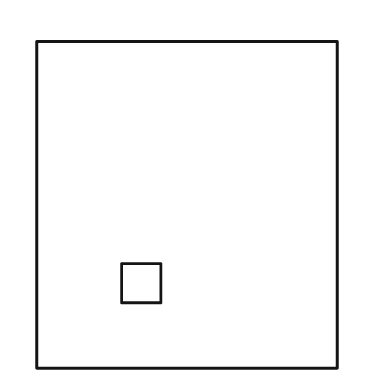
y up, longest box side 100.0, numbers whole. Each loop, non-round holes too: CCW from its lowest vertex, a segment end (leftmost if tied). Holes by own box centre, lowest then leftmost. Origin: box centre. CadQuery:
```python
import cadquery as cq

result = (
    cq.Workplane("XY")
    .moveTo(-46.0, -50.0)
    .lineTo(46.0, -50.0)
    .lineTo(46.0, 50.0)
    .lineTo(-46.0, 50.0)
    .close()
    .moveTo(-20.0, -30.0)
    .lineTo(-8.0, -30.0)
    .lineTo(-8.0, -18.0)
    .lineTo(-20.0, -18.0)
    .close()
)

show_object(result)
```